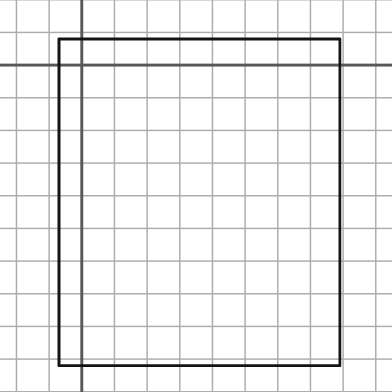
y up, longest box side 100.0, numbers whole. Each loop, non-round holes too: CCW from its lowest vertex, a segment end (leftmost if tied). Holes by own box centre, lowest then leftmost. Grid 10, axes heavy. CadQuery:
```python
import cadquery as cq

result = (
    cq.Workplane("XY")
    .moveTo(-7.0, -92.0)
    .lineTo(79.0, -92.0)
    .lineTo(79.0, 8.0)
    .lineTo(-7.0, 8.0)
    .close()
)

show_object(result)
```